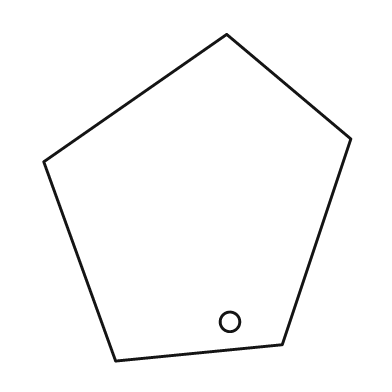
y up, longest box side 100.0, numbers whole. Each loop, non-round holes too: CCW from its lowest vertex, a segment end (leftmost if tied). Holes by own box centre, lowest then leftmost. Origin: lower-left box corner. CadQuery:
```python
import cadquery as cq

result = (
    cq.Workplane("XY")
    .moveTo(22.0, 0.0)
    .lineTo(73.0, 5.0)
    .lineTo(94.0, 68.0)
    .lineTo(56.0, 100.0)
    .lineTo(0.0, 61.0)
    .close()
    .moveTo(57.0, 12.0)
    .circle(3.0)
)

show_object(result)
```